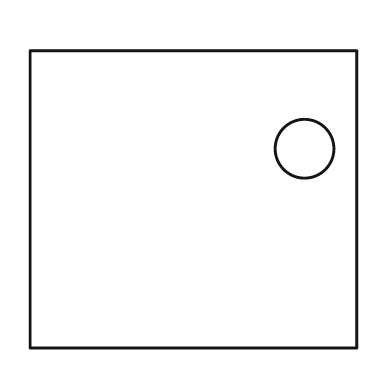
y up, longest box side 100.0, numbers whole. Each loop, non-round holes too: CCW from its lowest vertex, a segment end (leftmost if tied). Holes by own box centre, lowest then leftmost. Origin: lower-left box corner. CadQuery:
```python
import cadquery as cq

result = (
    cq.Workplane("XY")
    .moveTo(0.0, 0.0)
    .lineTo(100.0, 0.0)
    .lineTo(100.0, 91.0)
    .lineTo(0.0, 91.0)
    .close()
    .moveTo(84.0, 61.0)
    .circle(9.0)
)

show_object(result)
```